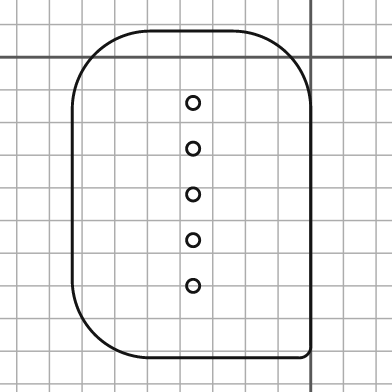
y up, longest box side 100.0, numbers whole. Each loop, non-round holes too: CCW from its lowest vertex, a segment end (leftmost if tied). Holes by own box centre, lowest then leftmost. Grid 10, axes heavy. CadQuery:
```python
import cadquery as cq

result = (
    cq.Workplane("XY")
    .moveTo(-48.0, -92.0)
    .lineTo(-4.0, -92.0)
    .threePointArc((-1.0, -91.0), (0.0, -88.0))
    .lineTo(0.0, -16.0)
    .threePointArc((-7.0, 1.0), (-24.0, 8.0))
    .lineTo(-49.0, 8.0)
    .threePointArc((-66.0, 1.0), (-73.0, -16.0))
    .lineTo(-73.0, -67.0)
    .threePointArc((-66.0, -85.0), (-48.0, -92.0))
    .close()
    .moveTo(-36.0, -70.0)
    .circle(2.0)
    .moveTo(-36.0, -56.0)
    .circle(2.0)
    .moveTo(-36.0, -42.0)
    .circle(2.0)
    .moveTo(-36.0, -28.0)
    .circle(2.0)
    .moveTo(-36.0, -14.0)
    .circle(2.0)
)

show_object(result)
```